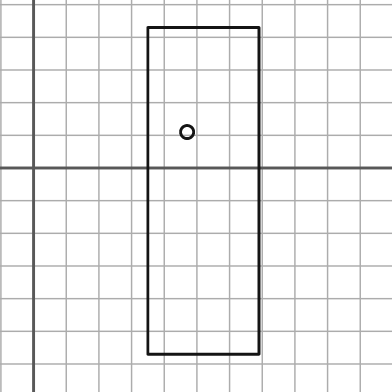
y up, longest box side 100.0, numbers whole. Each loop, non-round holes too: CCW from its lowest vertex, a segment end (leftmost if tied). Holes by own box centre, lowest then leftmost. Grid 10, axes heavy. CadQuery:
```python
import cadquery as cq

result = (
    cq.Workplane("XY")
    .moveTo(35.0, -57.0)
    .lineTo(69.0, -57.0)
    .lineTo(69.0, 43.0)
    .lineTo(35.0, 43.0)
    .close()
    .moveTo(47.0, 11.0)
    .circle(2.0)
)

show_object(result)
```